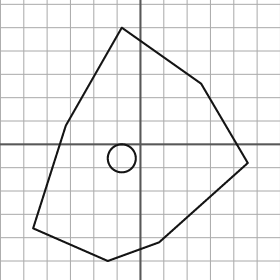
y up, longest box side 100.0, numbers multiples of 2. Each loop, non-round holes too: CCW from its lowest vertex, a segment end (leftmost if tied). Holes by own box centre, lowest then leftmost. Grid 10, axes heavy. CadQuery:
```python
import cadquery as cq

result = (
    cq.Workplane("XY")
    .moveTo(-14.0, -50.0)
    .lineTo(8.0, -42.0)
    .lineTo(46.0, -8.0)
    .lineTo(26.0, 26.0)
    .lineTo(-8.0, 50.0)
    .lineTo(-32.0, 8.0)
    .lineTo(-46.0, -36.0)
    .close()
    .moveTo(-8.0, -6.0)
    .circle(6.0)
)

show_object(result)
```